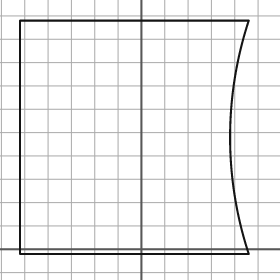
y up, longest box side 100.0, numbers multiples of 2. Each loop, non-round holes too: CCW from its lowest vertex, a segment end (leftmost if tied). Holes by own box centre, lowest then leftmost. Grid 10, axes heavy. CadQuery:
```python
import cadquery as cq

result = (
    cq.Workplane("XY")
    .moveTo(-52.0, -2.0)
    .lineTo(46.0, -2.0)
    .threePointArc((38.0, 48.0), (46.0, 98.0))
    .lineTo(-52.0, 98.0)
    .close()
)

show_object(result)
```